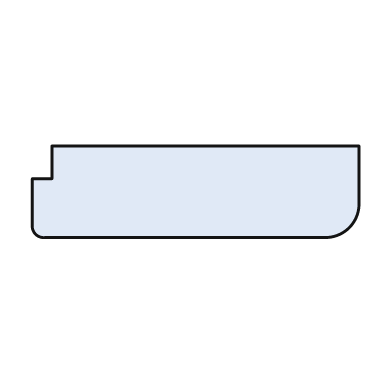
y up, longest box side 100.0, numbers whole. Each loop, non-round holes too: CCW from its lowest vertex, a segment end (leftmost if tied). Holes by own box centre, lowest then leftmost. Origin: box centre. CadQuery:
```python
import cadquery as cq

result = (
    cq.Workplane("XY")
    .moveTo(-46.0, -14.0)
    .lineTo(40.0, -14.0)
    .threePointArc((47.0, -11.0), (50.0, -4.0))
    .lineTo(50.0, 14.0)
    .lineTo(-44.0, 14.0)
    .lineTo(-44.0, 4.0)
    .lineTo(-50.0, 4.0)
    .lineTo(-50.0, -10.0)
    .threePointArc((-49.0, -13.0), (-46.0, -14.0))
    .close()
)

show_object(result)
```